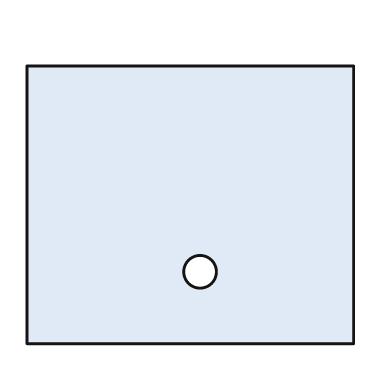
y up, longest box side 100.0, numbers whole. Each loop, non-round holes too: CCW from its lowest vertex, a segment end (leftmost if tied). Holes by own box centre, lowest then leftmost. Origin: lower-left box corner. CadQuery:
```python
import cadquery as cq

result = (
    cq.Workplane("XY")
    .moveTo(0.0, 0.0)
    .lineTo(100.0, 0.0)
    .lineTo(100.0, 85.0)
    .lineTo(0.0, 85.0)
    .close()
    .moveTo(53.0, 22.0)
    .circle(5.0)
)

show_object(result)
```